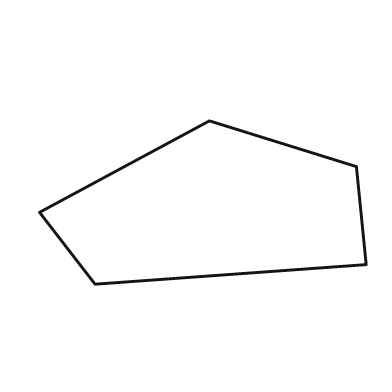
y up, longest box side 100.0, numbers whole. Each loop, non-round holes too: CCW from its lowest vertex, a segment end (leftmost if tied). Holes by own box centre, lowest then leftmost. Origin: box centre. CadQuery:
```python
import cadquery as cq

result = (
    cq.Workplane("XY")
    .moveTo(-33.0, -25.0)
    .lineTo(50.0, -19.0)
    .lineTo(47.0, 11.0)
    .lineTo(2.0, 25.0)
    .lineTo(-50.0, -3.0)
    .close()
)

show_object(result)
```